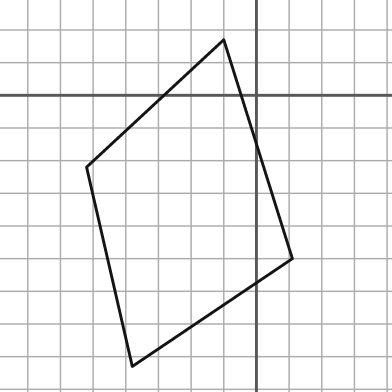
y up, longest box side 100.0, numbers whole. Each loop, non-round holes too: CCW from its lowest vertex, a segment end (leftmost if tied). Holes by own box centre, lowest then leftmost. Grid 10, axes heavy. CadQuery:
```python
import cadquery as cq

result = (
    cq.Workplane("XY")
    .moveTo(-38.0, -83.0)
    .lineTo(11.0, -50.0)
    .lineTo(-10.0, 17.0)
    .lineTo(-52.0, -22.0)
    .close()
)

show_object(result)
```